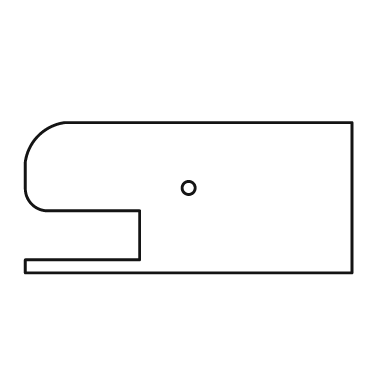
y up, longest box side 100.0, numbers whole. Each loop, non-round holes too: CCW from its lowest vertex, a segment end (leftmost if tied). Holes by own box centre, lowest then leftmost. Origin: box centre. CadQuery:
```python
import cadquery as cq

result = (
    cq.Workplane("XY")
    .moveTo(-50.0, -23.0)
    .lineTo(50.0, -23.0)
    .lineTo(50.0, 23.0)
    .lineTo(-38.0, 23.0)
    .threePointArc((-46.0, 19.0), (-50.0, 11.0))
    .lineTo(-50.0, 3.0)
    .threePointArc((-48.0, -2.0), (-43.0, -4.0))
    .lineTo(-15.0, -4.0)
    .lineTo(-15.0, -19.0)
    .lineTo(-50.0, -19.0)
    .close()
    .moveTo(0.0, 3.0)
    .circle(2.0)
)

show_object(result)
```